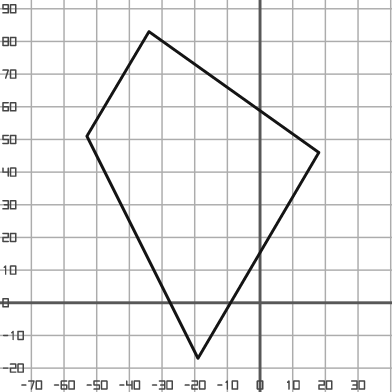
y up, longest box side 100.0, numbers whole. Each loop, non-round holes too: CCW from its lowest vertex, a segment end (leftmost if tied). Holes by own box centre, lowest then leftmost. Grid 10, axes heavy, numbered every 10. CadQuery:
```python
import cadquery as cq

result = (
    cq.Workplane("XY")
    .moveTo(-19.0, -17.0)
    .lineTo(18.0, 46.0)
    .lineTo(-34.0, 83.0)
    .lineTo(-53.0, 51.0)
    .close()
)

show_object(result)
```